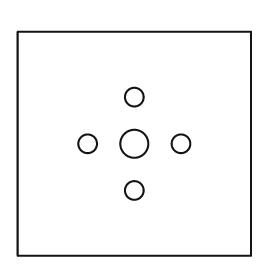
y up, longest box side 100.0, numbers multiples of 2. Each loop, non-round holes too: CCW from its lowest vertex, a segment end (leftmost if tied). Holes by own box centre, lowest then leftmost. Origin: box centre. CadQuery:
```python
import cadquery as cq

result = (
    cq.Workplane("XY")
    .moveTo(-50.0, -48.0)
    .lineTo(50.0, -48.0)
    .lineTo(50.0, 48.0)
    .lineTo(-50.0, 48.0)
    .close()
    .moveTo(0.0, -20.0)
    .circle(4.0)
    .moveTo(-20.0, 0.0)
    .circle(4.0)
    .moveTo(0.0, 0.0)
    .circle(6.0)
    .moveTo(20.0, 0.0)
    .circle(4.0)
    .moveTo(0.0, 20.0)
    .circle(4.0)
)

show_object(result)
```